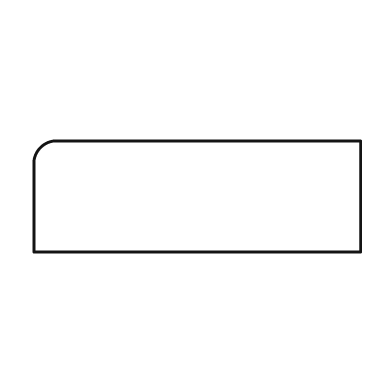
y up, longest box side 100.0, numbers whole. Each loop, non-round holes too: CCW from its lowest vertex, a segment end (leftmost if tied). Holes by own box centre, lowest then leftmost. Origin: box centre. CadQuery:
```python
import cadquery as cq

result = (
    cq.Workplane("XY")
    .moveTo(-50.0, -17.0)
    .lineTo(50.0, -17.0)
    .lineTo(50.0, 17.0)
    .lineTo(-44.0, 17.0)
    .threePointArc((-48.0, 15.0), (-50.0, 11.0))
    .close()
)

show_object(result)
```